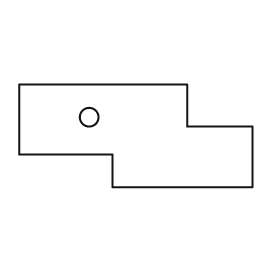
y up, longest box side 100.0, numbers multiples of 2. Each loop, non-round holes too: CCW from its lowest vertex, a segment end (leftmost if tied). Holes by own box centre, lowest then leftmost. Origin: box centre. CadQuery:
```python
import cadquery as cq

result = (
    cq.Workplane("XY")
    .moveTo(-10.0, -22.0)
    .lineTo(50.0, -22.0)
    .lineTo(50.0, 4.0)
    .lineTo(22.0, 4.0)
    .lineTo(22.0, 22.0)
    .lineTo(-50.0, 22.0)
    .lineTo(-50.0, -8.0)
    .lineTo(-10.0, -8.0)
    .close()
    .moveTo(-20.0, 8.0)
    .circle(4.0)
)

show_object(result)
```